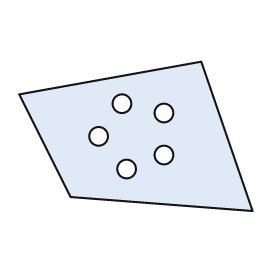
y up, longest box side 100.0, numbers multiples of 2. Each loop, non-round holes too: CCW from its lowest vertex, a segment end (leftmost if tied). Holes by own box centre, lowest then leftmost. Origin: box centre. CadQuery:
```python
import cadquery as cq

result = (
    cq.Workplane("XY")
    .moveTo(50.0, -32.0)
    .lineTo(28.0, 32.0)
    .lineTo(-50.0, 18.0)
    .lineTo(-28.0, -26.0)
    .close()
    .moveTo(-4.0, -14.0)
    .circle(4.0)
    .moveTo(12.0, -8.0)
    .circle(4.0)
    .moveTo(-16.0, 0.0)
    .circle(4.0)
    .moveTo(12.0, 10.0)
    .circle(4.0)
    .moveTo(-6.0, 14.0)
    .circle(4.0)
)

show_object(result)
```